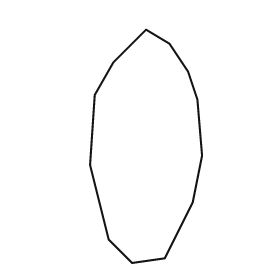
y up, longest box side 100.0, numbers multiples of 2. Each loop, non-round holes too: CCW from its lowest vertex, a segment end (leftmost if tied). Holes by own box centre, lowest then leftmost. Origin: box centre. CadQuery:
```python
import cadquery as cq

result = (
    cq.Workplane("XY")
    .moveTo(-6.0, -50.0)
    .lineTo(8.0, -48.0)
    .lineTo(20.0, -24.0)
    .lineTo(24.0, -4.0)
    .lineTo(22.0, 20.0)
    .lineTo(18.0, 32.0)
    .lineTo(10.0, 44.0)
    .lineTo(0.0, 50.0)
    .lineTo(-14.0, 36.0)
    .lineTo(-22.0, 22.0)
    .lineTo(-24.0, -8.0)
    .lineTo(-16.0, -40.0)
    .close()
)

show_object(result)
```